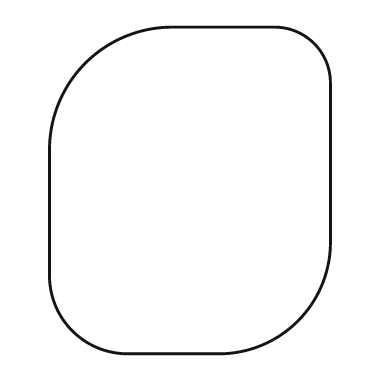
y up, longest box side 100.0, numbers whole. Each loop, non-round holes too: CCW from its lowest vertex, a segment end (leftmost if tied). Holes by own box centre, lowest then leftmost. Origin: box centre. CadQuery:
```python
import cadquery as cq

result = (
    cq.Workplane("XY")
    .moveTo(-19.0, -50.0)
    .lineTo(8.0, -50.0)
    .threePointArc((33.0, -40.0), (43.0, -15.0))
    .lineTo(43.0, 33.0)
    .threePointArc((38.0, 45.0), (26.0, 50.0))
    .lineTo(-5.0, 50.0)
    .threePointArc((-32.0, 39.0), (-43.0, 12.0))
    .lineTo(-43.0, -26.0)
    .threePointArc((-36.0, -43.0), (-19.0, -50.0))
    .close()
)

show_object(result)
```